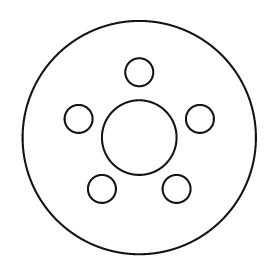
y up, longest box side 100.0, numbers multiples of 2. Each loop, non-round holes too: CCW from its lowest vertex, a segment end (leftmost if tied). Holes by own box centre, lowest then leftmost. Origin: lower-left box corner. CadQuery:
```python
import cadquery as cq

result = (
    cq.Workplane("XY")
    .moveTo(50.0, 50.0)
    .circle(50.0)
    .moveTo(34.0, 28.0)
    .circle(6.0)
    .moveTo(66.0, 28.0)
    .circle(6.0)
    .moveTo(50.0, 50.0)
    .circle(16.0)
    .moveTo(24.0, 58.0)
    .circle(6.0)
    .moveTo(76.0, 58.0)
    .circle(6.0)
    .moveTo(50.0, 78.0)
    .circle(6.0)
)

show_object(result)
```